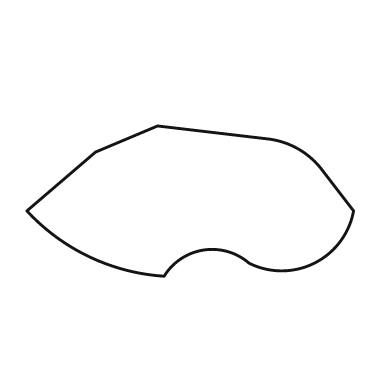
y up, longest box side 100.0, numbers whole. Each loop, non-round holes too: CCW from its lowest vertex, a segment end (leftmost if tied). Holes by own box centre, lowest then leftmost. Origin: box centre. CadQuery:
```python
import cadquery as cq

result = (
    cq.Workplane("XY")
    .moveTo(-8.0, -23.0)
    .threePointArc((4.0, -15.0), (18.0, -19.0))
    .threePointArc((38.0, -19.0), (50.0, -3.0))
    .lineTo(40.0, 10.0)
    .threePointArc((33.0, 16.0), (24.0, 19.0))
    .lineTo(-10.0, 23.0)
    .lineTo(-29.0, 15.0)
    .lineTo(-50.0, -3.0)
    .threePointArc((-31.0, -17.0), (-8.0, -23.0))
    .close()
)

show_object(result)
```